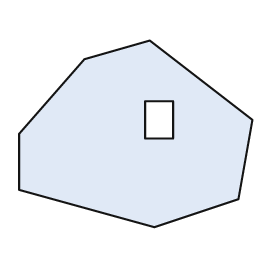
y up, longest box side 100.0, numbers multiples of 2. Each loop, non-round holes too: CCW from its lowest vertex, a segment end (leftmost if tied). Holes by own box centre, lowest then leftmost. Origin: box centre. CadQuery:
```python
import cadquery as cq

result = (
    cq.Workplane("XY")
    .moveTo(8.0, -40.0)
    .lineTo(44.0, -28.0)
    .lineTo(50.0, 6.0)
    .lineTo(6.0, 40.0)
    .lineTo(-22.0, 32.0)
    .lineTo(-50.0, 0.0)
    .lineTo(-50.0, -24.0)
    .close()
    .moveTo(4.0, -2.0)
    .lineTo(16.0, -2.0)
    .lineTo(16.0, 14.0)
    .lineTo(4.0, 14.0)
    .close()
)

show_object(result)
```